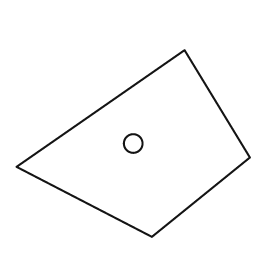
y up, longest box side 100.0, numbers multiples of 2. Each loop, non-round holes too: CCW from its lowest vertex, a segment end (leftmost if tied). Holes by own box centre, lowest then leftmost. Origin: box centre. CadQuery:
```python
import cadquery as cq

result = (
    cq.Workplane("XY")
    .moveTo(8.0, -40.0)
    .lineTo(50.0, -6.0)
    .lineTo(22.0, 40.0)
    .lineTo(-50.0, -10.0)
    .close()
    .moveTo(0.0, 0.0)
    .circle(4.0)
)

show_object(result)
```